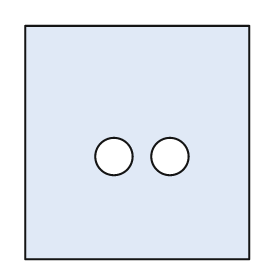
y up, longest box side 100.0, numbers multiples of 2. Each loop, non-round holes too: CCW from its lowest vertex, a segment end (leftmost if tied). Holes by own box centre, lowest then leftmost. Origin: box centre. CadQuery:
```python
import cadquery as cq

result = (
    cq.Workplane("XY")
    .moveTo(-48.0, -50.0)
    .lineTo(48.0, -50.0)
    .lineTo(48.0, 50.0)
    .lineTo(-48.0, 50.0)
    .close()
    .moveTo(-10.0, -6.0)
    .circle(8.0)
    .moveTo(14.0, -6.0)
    .circle(8.0)
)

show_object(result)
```